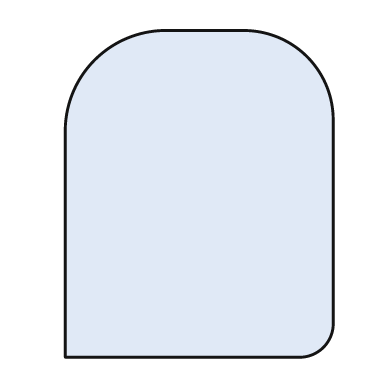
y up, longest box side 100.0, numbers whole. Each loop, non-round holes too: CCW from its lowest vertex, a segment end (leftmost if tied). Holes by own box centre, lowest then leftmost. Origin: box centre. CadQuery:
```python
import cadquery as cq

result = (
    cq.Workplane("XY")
    .moveTo(-41.0, -50.0)
    .lineTo(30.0, -50.0)
    .threePointArc((38.0, -47.0), (41.0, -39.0))
    .lineTo(41.0, 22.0)
    .threePointArc((33.0, 42.0), (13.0, 50.0))
    .lineTo(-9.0, 50.0)
    .threePointArc((-32.0, 41.0), (-41.0, 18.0))
    .close()
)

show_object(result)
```